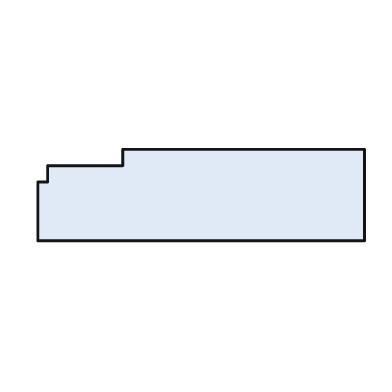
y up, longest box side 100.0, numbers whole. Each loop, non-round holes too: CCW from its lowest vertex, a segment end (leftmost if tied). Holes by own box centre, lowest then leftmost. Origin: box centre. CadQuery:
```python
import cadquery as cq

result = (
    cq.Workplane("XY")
    .moveTo(-50.0, -14.0)
    .lineTo(50.0, -14.0)
    .lineTo(50.0, 14.0)
    .lineTo(-24.0, 14.0)
    .lineTo(-24.0, 9.0)
    .lineTo(-47.0, 9.0)
    .lineTo(-47.0, 4.0)
    .lineTo(-50.0, 4.0)
    .close()
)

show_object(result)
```